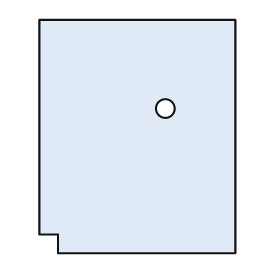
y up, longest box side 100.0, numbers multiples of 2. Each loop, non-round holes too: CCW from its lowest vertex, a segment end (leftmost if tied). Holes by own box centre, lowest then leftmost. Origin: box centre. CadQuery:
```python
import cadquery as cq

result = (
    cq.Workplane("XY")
    .moveTo(-34.0, -50.0)
    .lineTo(42.0, -50.0)
    .lineTo(42.0, 50.0)
    .lineTo(-42.0, 50.0)
    .lineTo(-42.0, -42.0)
    .lineTo(-34.0, -42.0)
    .close()
    .moveTo(12.0, 12.0)
    .circle(4.0)
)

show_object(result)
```